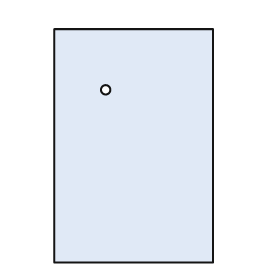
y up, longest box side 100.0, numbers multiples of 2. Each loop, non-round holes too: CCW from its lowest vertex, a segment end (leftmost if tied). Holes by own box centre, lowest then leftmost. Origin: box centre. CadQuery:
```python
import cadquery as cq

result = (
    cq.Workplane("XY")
    .moveTo(-34.0, -50.0)
    .lineTo(34.0, -50.0)
    .lineTo(34.0, 50.0)
    .lineTo(-34.0, 50.0)
    .close()
    .moveTo(-12.0, 24.0)
    .circle(2.0)
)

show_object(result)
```